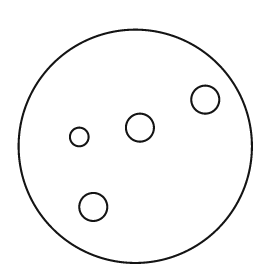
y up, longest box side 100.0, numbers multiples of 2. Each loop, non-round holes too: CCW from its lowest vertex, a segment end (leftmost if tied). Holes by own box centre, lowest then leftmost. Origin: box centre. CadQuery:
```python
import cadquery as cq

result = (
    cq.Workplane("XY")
    .moveTo(0.0, 0.0)
    .circle(50.0)
    .moveTo(-18.0, -26.0)
    .circle(6.0)
    .moveTo(-24.0, 4.0)
    .circle(4.0)
    .moveTo(2.0, 8.0)
    .circle(6.0)
    .moveTo(30.0, 20.0)
    .circle(6.0)
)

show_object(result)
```